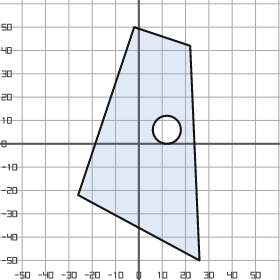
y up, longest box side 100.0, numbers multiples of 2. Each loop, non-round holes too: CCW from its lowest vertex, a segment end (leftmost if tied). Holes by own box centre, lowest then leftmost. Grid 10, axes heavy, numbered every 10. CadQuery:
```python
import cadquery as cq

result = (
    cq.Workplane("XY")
    .moveTo(26.0, -50.0)
    .lineTo(22.0, 42.0)
    .lineTo(-2.0, 50.0)
    .lineTo(-26.0, -22.0)
    .close()
    .moveTo(12.0, 6.0)
    .circle(6.0)
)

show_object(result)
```